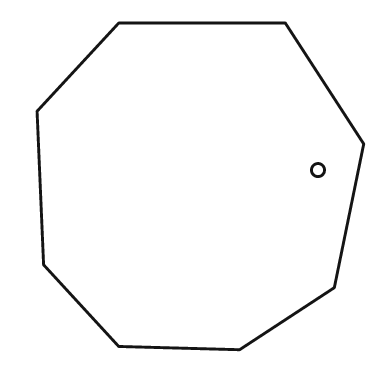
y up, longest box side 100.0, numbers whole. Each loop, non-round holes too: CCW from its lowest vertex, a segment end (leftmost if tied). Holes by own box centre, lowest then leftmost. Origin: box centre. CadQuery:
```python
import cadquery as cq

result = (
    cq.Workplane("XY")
    .moveTo(12.0, -50.0)
    .lineTo(41.0, -31.0)
    .lineTo(50.0, 13.0)
    .lineTo(26.0, 50.0)
    .lineTo(-25.0, 50.0)
    .lineTo(-50.0, 23.0)
    .lineTo(-48.0, -24.0)
    .lineTo(-25.0, -49.0)
    .close()
    .moveTo(36.0, 5.0)
    .circle(2.0)
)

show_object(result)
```